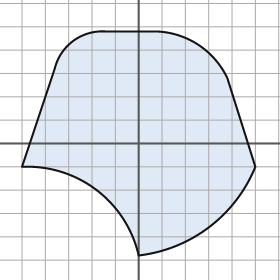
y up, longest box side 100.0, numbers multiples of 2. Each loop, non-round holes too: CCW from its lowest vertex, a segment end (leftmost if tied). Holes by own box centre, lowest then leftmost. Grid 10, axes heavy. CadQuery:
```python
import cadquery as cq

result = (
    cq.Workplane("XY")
    .moveTo(0.0, -48.0)
    .threePointArc((30.0, -36.0), (50.0, -10.0))
    .lineTo(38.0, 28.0)
    .threePointArc((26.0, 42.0), (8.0, 48.0))
    .lineTo(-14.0, 48.0)
    .threePointArc((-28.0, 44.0), (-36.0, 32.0))
    .lineTo(-50.0, -10.0)
    .threePointArc((-18.0, -20.0), (0.0, -48.0))
    .close()
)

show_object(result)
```